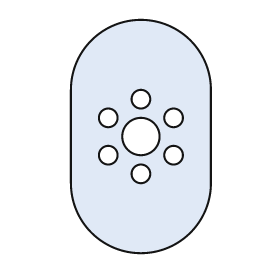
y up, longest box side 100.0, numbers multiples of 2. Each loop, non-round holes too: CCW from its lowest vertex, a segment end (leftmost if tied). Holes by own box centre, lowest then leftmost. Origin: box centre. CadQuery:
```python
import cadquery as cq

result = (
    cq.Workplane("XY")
    .moveTo(-30.0, -20.0)
    .threePointArc((0.0, -50.0), (30.0, -20.0))
    .lineTo(30.0, 20.0)
    .threePointArc((0.0, 50.0), (-30.0, 20.0))
    .close()
    .moveTo(0.0, -16.0)
    .circle(4.0)
    .moveTo(-14.0, -8.0)
    .circle(4.0)
    .moveTo(14.0, -8.0)
    .circle(4.0)
    .moveTo(0.0, 0.0)
    .circle(8.0)
    .moveTo(-14.0, 8.0)
    .circle(4.0)
    .moveTo(14.0, 8.0)
    .circle(4.0)
    .moveTo(0.0, 16.0)
    .circle(4.0)
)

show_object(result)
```